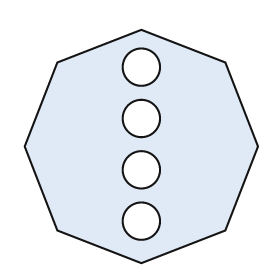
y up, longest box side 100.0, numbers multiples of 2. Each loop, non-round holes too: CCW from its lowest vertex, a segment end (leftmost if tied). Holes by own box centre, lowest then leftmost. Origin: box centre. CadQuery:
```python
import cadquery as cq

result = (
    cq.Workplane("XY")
    .moveTo(0.0, -50.0)
    .lineTo(36.0, -36.0)
    .lineTo(50.0, 0.0)
    .lineTo(36.0, 36.0)
    .lineTo(0.0, 50.0)
    .lineTo(-36.0, 36.0)
    .lineTo(-50.0, 0.0)
    .lineTo(-36.0, -36.0)
    .close()
    .moveTo(0.0, -32.0)
    .circle(8.0)
    .moveTo(0.0, -10.0)
    .circle(8.0)
    .moveTo(0.0, 12.0)
    .circle(8.0)
    .moveTo(0.0, 34.0)
    .circle(8.0)
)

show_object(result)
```